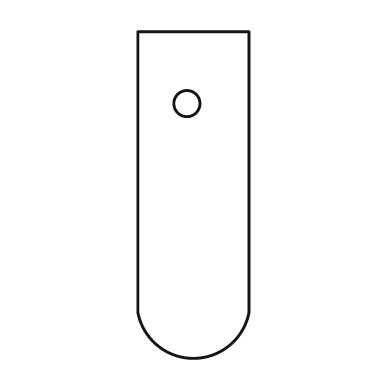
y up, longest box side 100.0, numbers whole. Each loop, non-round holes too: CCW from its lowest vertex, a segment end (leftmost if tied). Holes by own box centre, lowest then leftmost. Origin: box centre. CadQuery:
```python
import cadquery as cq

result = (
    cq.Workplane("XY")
    .moveTo(-17.0, -36.0)
    .threePointArc((0.0, -50.0), (17.0, -36.0))
    .lineTo(17.0, 50.0)
    .lineTo(-17.0, 50.0)
    .close()
    .moveTo(-2.0, 28.0)
    .circle(4.0)
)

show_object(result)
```